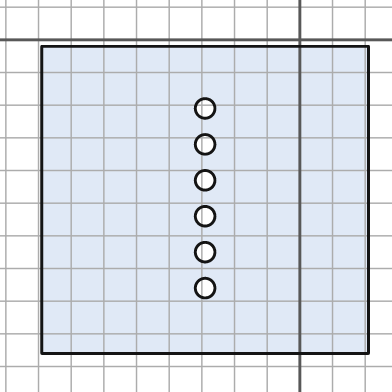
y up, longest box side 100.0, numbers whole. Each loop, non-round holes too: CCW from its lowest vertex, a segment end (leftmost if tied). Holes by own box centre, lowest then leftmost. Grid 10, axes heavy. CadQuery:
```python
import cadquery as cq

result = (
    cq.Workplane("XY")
    .moveTo(-79.0, -96.0)
    .lineTo(21.0, -96.0)
    .lineTo(21.0, -2.0)
    .lineTo(-79.0, -2.0)
    .close()
    .moveTo(-29.0, -76.0)
    .circle(3.0)
    .moveTo(-29.0, -65.0)
    .circle(3.0)
    .moveTo(-29.0, -54.0)
    .circle(3.0)
    .moveTo(-29.0, -43.0)
    .circle(3.0)
    .moveTo(-29.0, -32.0)
    .circle(3.0)
    .moveTo(-29.0, -21.0)
    .circle(3.0)
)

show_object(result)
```